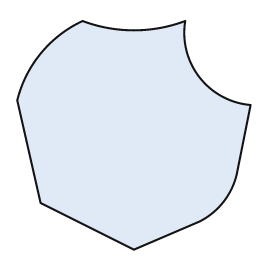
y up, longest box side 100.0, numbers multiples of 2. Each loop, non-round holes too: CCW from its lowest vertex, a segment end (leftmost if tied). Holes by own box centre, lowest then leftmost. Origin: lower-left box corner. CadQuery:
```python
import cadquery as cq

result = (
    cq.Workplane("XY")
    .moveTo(50.0, 0.0)
    .lineTo(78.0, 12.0)
    .threePointArc((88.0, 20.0), (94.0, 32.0))
    .lineTo(100.0, 62.0)
    .threePointArc((78.0, 74.0), (72.0, 98.0))
    .threePointArc((50.0, 94.0), (28.0, 98.0))
    .threePointArc((10.0, 84.0), (0.0, 64.0))
    .lineTo(10.0, 20.0)
    .close()
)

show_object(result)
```